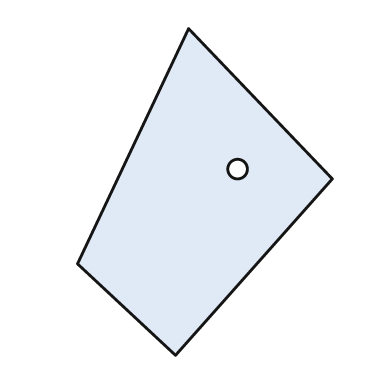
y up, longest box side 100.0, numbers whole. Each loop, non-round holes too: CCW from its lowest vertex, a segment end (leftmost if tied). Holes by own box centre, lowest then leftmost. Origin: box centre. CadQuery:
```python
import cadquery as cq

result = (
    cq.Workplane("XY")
    .moveTo(-9.0, -50.0)
    .lineTo(39.0, 4.0)
    .lineTo(-5.0, 50.0)
    .lineTo(-39.0, -22.0)
    .close()
    .moveTo(10.0, 7.0)
    .circle(3.0)
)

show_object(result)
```